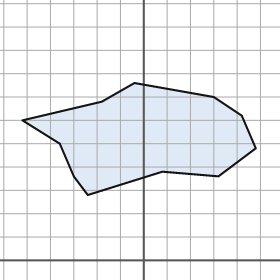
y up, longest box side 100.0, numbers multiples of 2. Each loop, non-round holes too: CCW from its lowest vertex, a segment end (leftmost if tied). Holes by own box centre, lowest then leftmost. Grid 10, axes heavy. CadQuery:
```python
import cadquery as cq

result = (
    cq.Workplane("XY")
    .moveTo(-24.0, 28.0)
    .lineTo(8.0, 38.0)
    .lineTo(32.0, 36.0)
    .lineTo(48.0, 48.0)
    .lineTo(42.0, 62.0)
    .lineTo(30.0, 70.0)
    .lineTo(-4.0, 76.0)
    .lineTo(-18.0, 68.0)
    .lineTo(-52.0, 60.0)
    .lineTo(-36.0, 50.0)
    .lineTo(-30.0, 36.0)
    .close()
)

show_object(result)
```